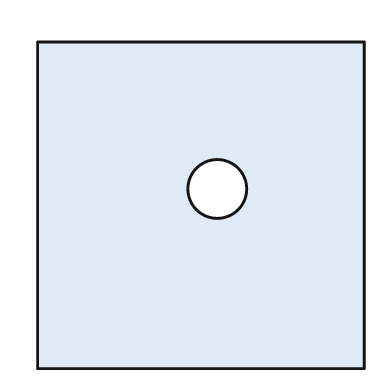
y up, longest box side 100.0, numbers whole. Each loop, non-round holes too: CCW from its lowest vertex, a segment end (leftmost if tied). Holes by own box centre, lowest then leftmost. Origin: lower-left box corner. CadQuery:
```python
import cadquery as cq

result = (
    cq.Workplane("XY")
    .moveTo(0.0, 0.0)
    .lineTo(100.0, 0.0)
    .lineTo(100.0, 100.0)
    .lineTo(0.0, 100.0)
    .close()
    .moveTo(55.0, 55.0)
    .circle(9.0)
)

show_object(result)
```